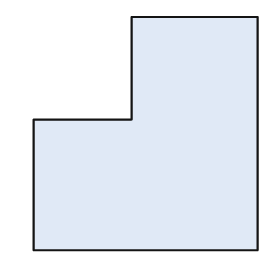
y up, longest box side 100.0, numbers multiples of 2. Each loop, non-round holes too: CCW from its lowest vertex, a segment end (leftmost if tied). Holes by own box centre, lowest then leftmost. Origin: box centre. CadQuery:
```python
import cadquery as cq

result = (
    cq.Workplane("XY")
    .moveTo(-48.0, -50.0)
    .lineTo(48.0, -50.0)
    .lineTo(48.0, 50.0)
    .lineTo(-6.0, 50.0)
    .lineTo(-6.0, 6.0)
    .lineTo(-48.0, 6.0)
    .close()
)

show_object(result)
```